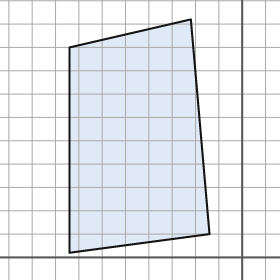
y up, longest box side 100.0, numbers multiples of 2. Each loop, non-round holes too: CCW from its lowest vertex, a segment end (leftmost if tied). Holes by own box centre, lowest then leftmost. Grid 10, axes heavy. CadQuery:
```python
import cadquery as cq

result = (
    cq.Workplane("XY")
    .moveTo(-74.0, 2.0)
    .lineTo(-14.0, 10.0)
    .lineTo(-22.0, 102.0)
    .lineTo(-74.0, 90.0)
    .close()
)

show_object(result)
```